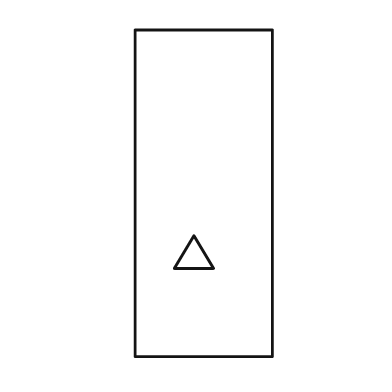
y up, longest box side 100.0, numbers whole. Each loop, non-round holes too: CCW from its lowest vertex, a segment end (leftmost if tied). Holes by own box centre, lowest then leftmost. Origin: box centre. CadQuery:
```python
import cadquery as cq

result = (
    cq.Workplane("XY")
    .moveTo(-21.0, -50.0)
    .lineTo(21.0, -50.0)
    .lineTo(21.0, 50.0)
    .lineTo(-21.0, 50.0)
    .close()
    .moveTo(-9.0, -23.0)
    .lineTo(3.0, -23.0)
    .lineTo(-3.0, -13.0)
    .close()
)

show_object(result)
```